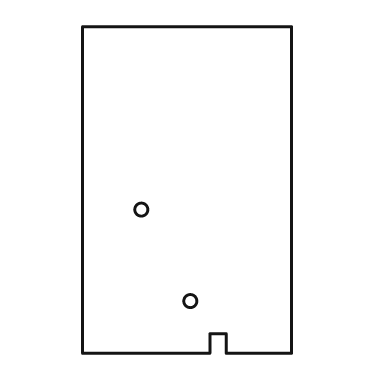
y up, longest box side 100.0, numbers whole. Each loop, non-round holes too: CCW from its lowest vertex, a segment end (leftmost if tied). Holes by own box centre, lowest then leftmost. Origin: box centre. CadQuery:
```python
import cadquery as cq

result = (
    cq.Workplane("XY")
    .moveTo(-32.0, -50.0)
    .lineTo(7.0, -50.0)
    .lineTo(7.0, -44.0)
    .lineTo(12.0, -44.0)
    .lineTo(12.0, -50.0)
    .lineTo(32.0, -50.0)
    .lineTo(32.0, 50.0)
    .lineTo(-32.0, 50.0)
    .close()
    .moveTo(1.0, -34.0)
    .circle(2.0)
    .moveTo(-14.0, -6.0)
    .circle(2.0)
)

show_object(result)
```